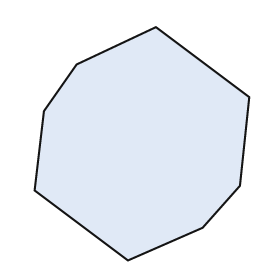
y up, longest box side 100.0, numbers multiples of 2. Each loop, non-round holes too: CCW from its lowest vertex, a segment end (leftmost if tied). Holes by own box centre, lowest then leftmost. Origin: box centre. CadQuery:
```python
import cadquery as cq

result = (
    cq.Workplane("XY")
    .moveTo(-6.0, -50.0)
    .lineTo(26.0, -36.0)
    .lineTo(42.0, -18.0)
    .lineTo(46.0, 20.0)
    .lineTo(6.0, 50.0)
    .lineTo(-28.0, 34.0)
    .lineTo(-42.0, 14.0)
    .lineTo(-46.0, -20.0)
    .close()
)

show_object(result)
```